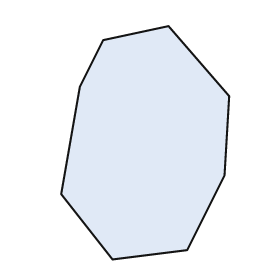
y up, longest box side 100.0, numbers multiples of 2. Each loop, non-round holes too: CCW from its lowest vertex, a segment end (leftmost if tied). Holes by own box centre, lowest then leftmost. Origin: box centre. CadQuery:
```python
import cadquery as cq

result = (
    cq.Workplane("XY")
    .moveTo(-14.0, -50.0)
    .lineTo(18.0, -46.0)
    .lineTo(34.0, -14.0)
    .lineTo(36.0, 20.0)
    .lineTo(10.0, 50.0)
    .lineTo(-18.0, 44.0)
    .lineTo(-28.0, 24.0)
    .lineTo(-36.0, -22.0)
    .close()
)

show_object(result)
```